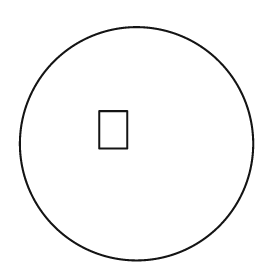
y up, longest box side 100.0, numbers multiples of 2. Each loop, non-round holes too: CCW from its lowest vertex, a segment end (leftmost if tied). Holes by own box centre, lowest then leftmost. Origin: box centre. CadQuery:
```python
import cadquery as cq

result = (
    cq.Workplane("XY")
    .moveTo(0.0, 0.0)
    .circle(50.0)
    .moveTo(-16.0, -2.0)
    .lineTo(-4.0, -2.0)
    .lineTo(-4.0, 14.0)
    .lineTo(-16.0, 14.0)
    .close()
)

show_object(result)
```